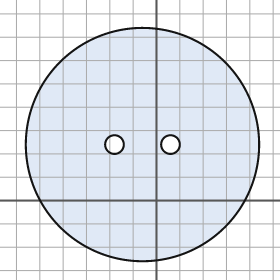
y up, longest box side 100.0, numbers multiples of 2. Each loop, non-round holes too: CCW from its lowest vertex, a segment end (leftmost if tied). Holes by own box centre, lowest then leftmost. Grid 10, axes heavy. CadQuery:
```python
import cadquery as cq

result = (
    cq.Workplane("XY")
    .moveTo(-6.0, 24.0)
    .circle(50.0)
    .moveTo(-18.0, 24.0)
    .circle(4.0)
    .moveTo(6.0, 24.0)
    .circle(4.0)
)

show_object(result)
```